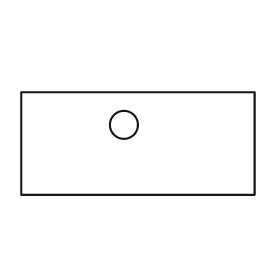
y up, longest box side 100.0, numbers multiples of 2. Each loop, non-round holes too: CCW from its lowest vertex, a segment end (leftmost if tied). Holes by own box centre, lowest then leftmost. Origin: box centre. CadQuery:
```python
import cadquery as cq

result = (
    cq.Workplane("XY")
    .moveTo(-50.0, -22.0)
    .lineTo(50.0, -22.0)
    .lineTo(50.0, 22.0)
    .lineTo(-50.0, 22.0)
    .close()
    .moveTo(-6.0, 8.0)
    .circle(6.0)
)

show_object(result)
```